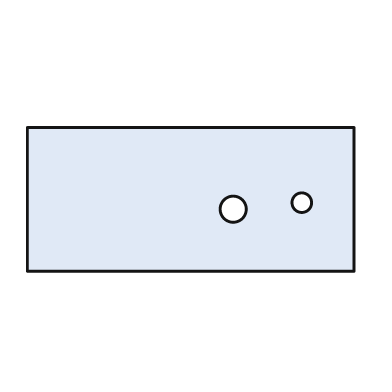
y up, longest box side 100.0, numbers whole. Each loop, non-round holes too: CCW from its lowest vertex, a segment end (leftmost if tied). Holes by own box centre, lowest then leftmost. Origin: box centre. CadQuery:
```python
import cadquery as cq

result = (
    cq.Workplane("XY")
    .moveTo(-50.0, -22.0)
    .lineTo(50.0, -22.0)
    .lineTo(50.0, 22.0)
    .lineTo(-50.0, 22.0)
    .close()
    .moveTo(13.0, -3.0)
    .circle(4.0)
    .moveTo(34.0, -1.0)
    .circle(3.0)
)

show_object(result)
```